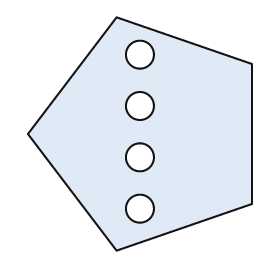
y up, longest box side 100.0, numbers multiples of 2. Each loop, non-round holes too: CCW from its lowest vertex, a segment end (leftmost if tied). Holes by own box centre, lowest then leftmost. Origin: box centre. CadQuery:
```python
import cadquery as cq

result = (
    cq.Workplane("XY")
    .moveTo(-10.0, -50.0)
    .lineTo(48.0, -30.0)
    .lineTo(48.0, 30.0)
    .lineTo(-10.0, 50.0)
    .lineTo(-48.0, 0.0)
    .close()
    .moveTo(0.0, -32.0)
    .circle(6.0)
    .moveTo(0.0, -10.0)
    .circle(6.0)
    .moveTo(0.0, 12.0)
    .circle(6.0)
    .moveTo(0.0, 34.0)
    .circle(6.0)
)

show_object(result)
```